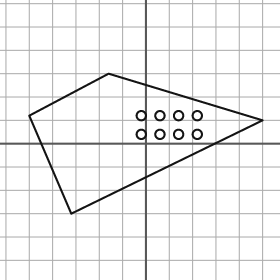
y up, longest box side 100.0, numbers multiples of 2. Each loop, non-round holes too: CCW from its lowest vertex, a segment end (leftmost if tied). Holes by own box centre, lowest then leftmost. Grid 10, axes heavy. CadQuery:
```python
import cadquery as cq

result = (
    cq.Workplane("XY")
    .moveTo(-32.0, -30.0)
    .lineTo(50.0, 10.0)
    .lineTo(-16.0, 30.0)
    .lineTo(-50.0, 12.0)
    .close()
    .moveTo(-2.0, 4.0)
    .circle(2.0)
    .moveTo(6.0, 4.0)
    .circle(2.0)
    .moveTo(14.0, 4.0)
    .circle(2.0)
    .moveTo(22.0, 4.0)
    .circle(2.0)
    .moveTo(-2.0, 12.0)
    .circle(2.0)
    .moveTo(6.0, 12.0)
    .circle(2.0)
    .moveTo(14.0, 12.0)
    .circle(2.0)
    .moveTo(22.0, 12.0)
    .circle(2.0)
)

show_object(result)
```